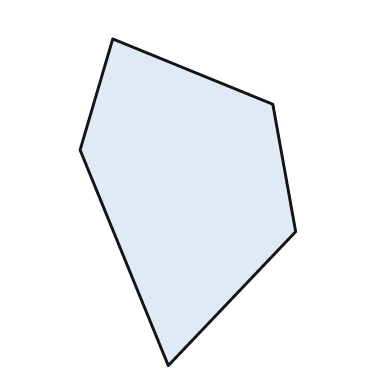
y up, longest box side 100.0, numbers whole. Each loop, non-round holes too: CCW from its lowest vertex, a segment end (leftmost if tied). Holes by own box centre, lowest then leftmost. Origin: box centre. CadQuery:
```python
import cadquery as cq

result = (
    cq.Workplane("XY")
    .moveTo(-6.0, -50.0)
    .lineTo(33.0, -9.0)
    .lineTo(26.0, 30.0)
    .lineTo(-23.0, 50.0)
    .lineTo(-33.0, 16.0)
    .close()
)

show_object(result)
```